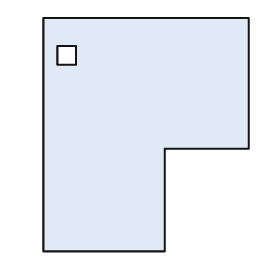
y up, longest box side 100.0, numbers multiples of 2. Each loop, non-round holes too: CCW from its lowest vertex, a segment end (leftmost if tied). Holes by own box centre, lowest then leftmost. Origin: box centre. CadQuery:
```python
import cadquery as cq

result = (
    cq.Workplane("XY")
    .moveTo(-44.0, -50.0)
    .lineTo(8.0, -50.0)
    .lineTo(8.0, -6.0)
    .lineTo(44.0, -6.0)
    .lineTo(44.0, 50.0)
    .lineTo(-44.0, 50.0)
    .close()
    .moveTo(-38.0, 30.0)
    .lineTo(-30.0, 30.0)
    .lineTo(-30.0, 38.0)
    .lineTo(-38.0, 38.0)
    .close()
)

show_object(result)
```